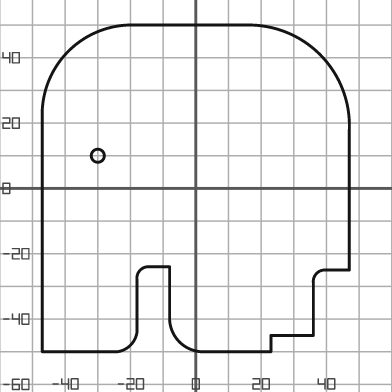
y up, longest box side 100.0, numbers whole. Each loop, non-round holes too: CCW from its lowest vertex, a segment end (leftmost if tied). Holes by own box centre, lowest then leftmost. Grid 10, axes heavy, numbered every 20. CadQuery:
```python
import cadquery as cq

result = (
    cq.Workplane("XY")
    .moveTo(-47.0, -50.0)
    .lineTo(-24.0, -50.0)
    .threePointArc((-20.0, -48.0), (-18.0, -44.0))
    .lineTo(-18.0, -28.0)
    .threePointArc((-17.0, -25.0), (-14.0, -24.0))
    .lineTo(-8.0, -24.0)
    .lineTo(-8.0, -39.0)
    .threePointArc((-5.0, -47.0), (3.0, -50.0))
    .lineTo(23.0, -50.0)
    .lineTo(23.0, -45.0)
    .lineTo(36.0, -45.0)
    .lineTo(36.0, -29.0)
    .threePointArc((37.0, -26.0), (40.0, -25.0))
    .lineTo(47.0, -25.0)
    .lineTo(47.0, 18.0)
    .threePointArc((38.0, 41.0), (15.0, 50.0))
    .lineTo(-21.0, 50.0)
    .threePointArc((-39.0, 42.0), (-47.0, 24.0))
    .close()
    .moveTo(-30.0, 10.0)
    .circle(2.0)
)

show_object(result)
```